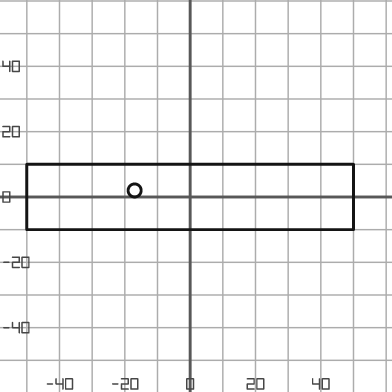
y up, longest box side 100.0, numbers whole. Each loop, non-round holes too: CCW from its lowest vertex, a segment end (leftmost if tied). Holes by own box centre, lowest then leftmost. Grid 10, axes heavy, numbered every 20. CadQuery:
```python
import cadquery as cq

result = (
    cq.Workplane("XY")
    .moveTo(-50.0, -10.0)
    .lineTo(50.0, -10.0)
    .lineTo(50.0, 10.0)
    .lineTo(-50.0, 10.0)
    .close()
    .moveTo(-17.0, 2.0)
    .circle(2.0)
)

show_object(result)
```